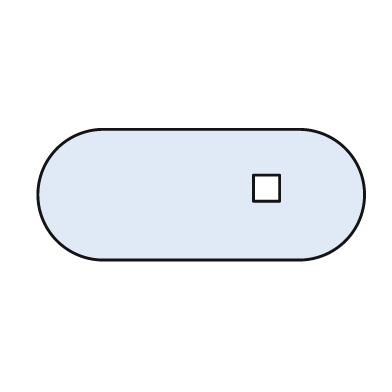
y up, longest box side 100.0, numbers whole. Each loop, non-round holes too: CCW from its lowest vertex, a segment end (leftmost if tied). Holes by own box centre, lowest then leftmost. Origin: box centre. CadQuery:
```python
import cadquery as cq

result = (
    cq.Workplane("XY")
    .moveTo(-30.0, -20.0)
    .lineTo(30.0, -20.0)
    .threePointArc((50.0, 0.0), (30.0, 20.0))
    .lineTo(-30.0, 20.0)
    .threePointArc((-50.0, 0.0), (-30.0, -20.0))
    .close()
    .moveTo(16.0, -2.0)
    .lineTo(24.0, -2.0)
    .lineTo(24.0, 6.0)
    .lineTo(16.0, 6.0)
    .close()
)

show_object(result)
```